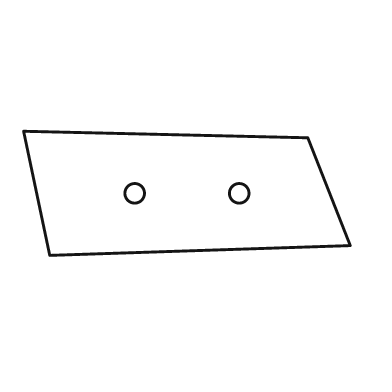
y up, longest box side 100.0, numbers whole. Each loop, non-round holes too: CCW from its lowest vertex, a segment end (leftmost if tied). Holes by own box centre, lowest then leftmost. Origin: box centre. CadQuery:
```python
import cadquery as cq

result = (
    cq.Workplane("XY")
    .moveTo(-42.0, -19.0)
    .lineTo(50.0, -16.0)
    .lineTo(37.0, 17.0)
    .lineTo(-50.0, 19.0)
    .close()
    .moveTo(-16.0, 0.0)
    .circle(3.0)
    .moveTo(16.0, 0.0)
    .circle(3.0)
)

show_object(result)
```